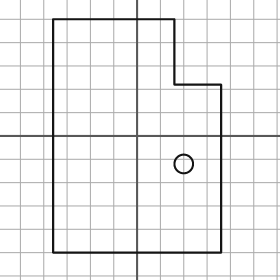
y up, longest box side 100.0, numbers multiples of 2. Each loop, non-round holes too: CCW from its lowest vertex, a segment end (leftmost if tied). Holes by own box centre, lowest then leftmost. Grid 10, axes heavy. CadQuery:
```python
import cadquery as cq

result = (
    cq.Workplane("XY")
    .moveTo(-36.0, -50.0)
    .lineTo(36.0, -50.0)
    .lineTo(36.0, 22.0)
    .lineTo(16.0, 22.0)
    .lineTo(16.0, 50.0)
    .lineTo(-36.0, 50.0)
    .close()
    .moveTo(20.0, -12.0)
    .circle(4.0)
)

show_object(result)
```